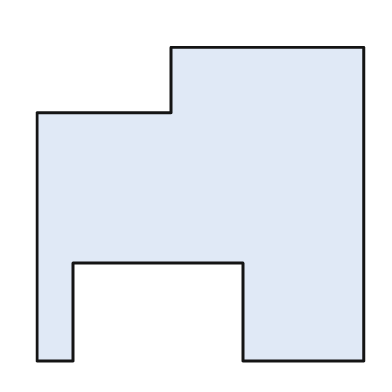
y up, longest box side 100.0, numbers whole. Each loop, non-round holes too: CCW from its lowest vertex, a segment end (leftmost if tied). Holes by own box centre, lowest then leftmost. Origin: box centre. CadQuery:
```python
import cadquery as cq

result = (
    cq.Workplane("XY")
    .moveTo(-50.0, -48.0)
    .lineTo(-39.0, -48.0)
    .lineTo(-39.0, -18.0)
    .lineTo(13.0, -18.0)
    .lineTo(13.0, -48.0)
    .lineTo(50.0, -48.0)
    .lineTo(50.0, 48.0)
    .lineTo(-9.0, 48.0)
    .lineTo(-9.0, 28.0)
    .lineTo(-50.0, 28.0)
    .close()
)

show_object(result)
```